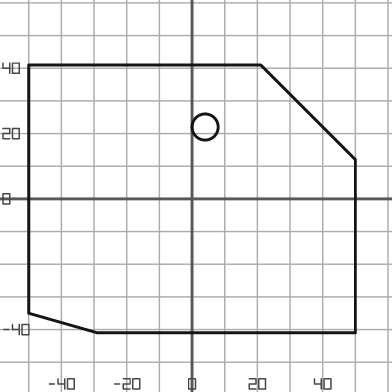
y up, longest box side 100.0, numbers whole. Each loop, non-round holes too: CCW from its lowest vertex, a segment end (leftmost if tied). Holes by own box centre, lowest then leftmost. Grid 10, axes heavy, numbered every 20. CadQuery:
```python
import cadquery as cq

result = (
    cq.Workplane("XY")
    .moveTo(-29.0, -41.0)
    .lineTo(50.0, -41.0)
    .lineTo(50.0, 12.0)
    .lineTo(21.0, 41.0)
    .lineTo(-50.0, 41.0)
    .lineTo(-50.0, -35.0)
    .close()
    .moveTo(4.0, 22.0)
    .circle(4.0)
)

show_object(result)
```